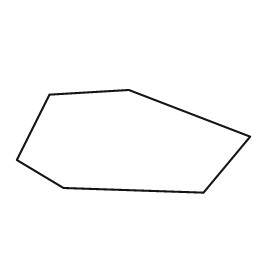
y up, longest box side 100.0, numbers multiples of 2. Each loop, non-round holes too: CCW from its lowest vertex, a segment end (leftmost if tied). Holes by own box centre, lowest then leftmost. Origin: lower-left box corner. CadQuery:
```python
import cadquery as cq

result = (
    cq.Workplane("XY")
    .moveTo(80.0, 0.0)
    .lineTo(100.0, 24.0)
    .lineTo(48.0, 44.0)
    .lineTo(14.0, 42.0)
    .lineTo(0.0, 14.0)
    .lineTo(20.0, 2.0)
    .close()
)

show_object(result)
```